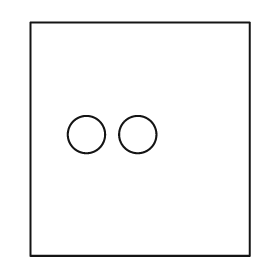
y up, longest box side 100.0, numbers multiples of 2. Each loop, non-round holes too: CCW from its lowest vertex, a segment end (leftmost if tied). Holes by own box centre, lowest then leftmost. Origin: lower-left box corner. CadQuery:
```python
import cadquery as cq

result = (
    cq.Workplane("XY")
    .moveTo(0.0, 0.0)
    .lineTo(94.0, 0.0)
    .lineTo(94.0, 100.0)
    .lineTo(0.0, 100.0)
    .close()
    .moveTo(24.0, 52.0)
    .circle(8.0)
    .moveTo(46.0, 52.0)
    .circle(8.0)
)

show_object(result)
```